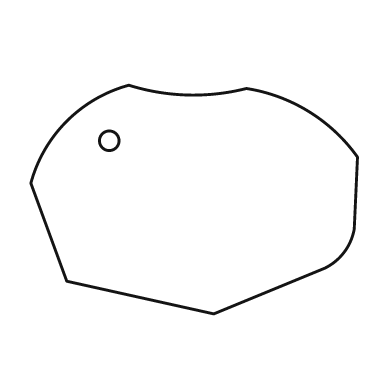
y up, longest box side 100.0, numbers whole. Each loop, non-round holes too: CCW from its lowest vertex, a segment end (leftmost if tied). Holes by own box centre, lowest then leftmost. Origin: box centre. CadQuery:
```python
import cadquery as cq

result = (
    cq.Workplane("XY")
    .moveTo(6.0, -35.0)
    .lineTo(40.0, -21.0)
    .threePointArc((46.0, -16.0), (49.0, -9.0))
    .lineTo(50.0, 13.0)
    .threePointArc((35.0, 27.0), (16.0, 34.0))
    .threePointArc((-2.0, 32.0), (-20.0, 35.0))
    .threePointArc((-39.0, 24.0), (-50.0, 5.0))
    .lineTo(-39.0, -25.0)
    .close()
    .moveTo(-26.0, 18.0)
    .circle(3.0)
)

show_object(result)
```